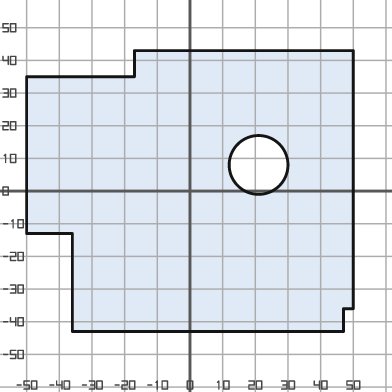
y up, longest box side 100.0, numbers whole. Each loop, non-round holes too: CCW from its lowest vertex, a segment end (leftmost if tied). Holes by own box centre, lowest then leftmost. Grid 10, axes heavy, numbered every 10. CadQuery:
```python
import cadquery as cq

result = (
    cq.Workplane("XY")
    .moveTo(-36.0, -43.0)
    .lineTo(47.0, -43.0)
    .lineTo(47.0, -36.0)
    .lineTo(50.0, -36.0)
    .lineTo(50.0, 43.0)
    .lineTo(-17.0, 43.0)
    .lineTo(-17.0, 35.0)
    .lineTo(-50.0, 35.0)
    .lineTo(-50.0, -13.0)
    .lineTo(-36.0, -13.0)
    .close()
    .moveTo(21.0, 8.0)
    .circle(9.0)
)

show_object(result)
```